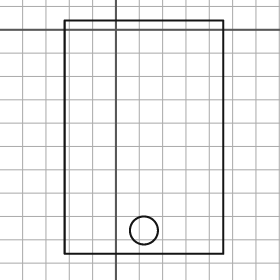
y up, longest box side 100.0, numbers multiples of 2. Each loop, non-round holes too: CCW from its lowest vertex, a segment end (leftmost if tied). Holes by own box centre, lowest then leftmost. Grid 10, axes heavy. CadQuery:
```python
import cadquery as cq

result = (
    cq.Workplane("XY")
    .moveTo(-22.0, -96.0)
    .lineTo(46.0, -96.0)
    .lineTo(46.0, 4.0)
    .lineTo(-22.0, 4.0)
    .close()
    .moveTo(12.0, -86.0)
    .circle(6.0)
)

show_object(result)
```